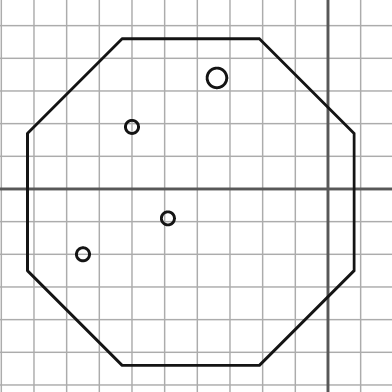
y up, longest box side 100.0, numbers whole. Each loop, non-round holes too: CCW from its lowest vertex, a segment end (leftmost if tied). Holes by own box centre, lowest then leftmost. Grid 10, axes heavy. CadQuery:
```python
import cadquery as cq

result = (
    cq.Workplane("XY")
    .moveTo(-63.0, -54.0)
    .lineTo(-21.0, -54.0)
    .lineTo(8.0, -25.0)
    .lineTo(8.0, 17.0)
    .lineTo(-21.0, 46.0)
    .lineTo(-63.0, 46.0)
    .lineTo(-92.0, 17.0)
    .lineTo(-92.0, -25.0)
    .close()
    .moveTo(-75.0, -20.0)
    .circle(2.0)
    .moveTo(-49.0, -9.0)
    .circle(2.0)
    .moveTo(-60.0, 19.0)
    .circle(2.0)
    .moveTo(-34.0, 34.0)
    .circle(3.0)
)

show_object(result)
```